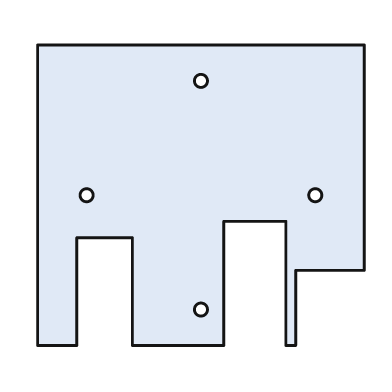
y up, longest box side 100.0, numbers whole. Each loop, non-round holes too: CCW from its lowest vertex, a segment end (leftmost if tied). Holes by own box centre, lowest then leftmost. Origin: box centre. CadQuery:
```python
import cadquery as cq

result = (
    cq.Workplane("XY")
    .moveTo(-50.0, -46.0)
    .lineTo(-38.0, -46.0)
    .lineTo(-38.0, -13.0)
    .lineTo(-21.0, -13.0)
    .lineTo(-21.0, -46.0)
    .lineTo(7.0, -46.0)
    .lineTo(7.0, -8.0)
    .lineTo(26.0, -8.0)
    .lineTo(26.0, -46.0)
    .lineTo(29.0, -46.0)
    .lineTo(29.0, -23.0)
    .lineTo(50.0, -23.0)
    .lineTo(50.0, 46.0)
    .lineTo(-50.0, 46.0)
    .close()
    .moveTo(0.0, -35.0)
    .circle(2.0)
    .moveTo(-35.0, 0.0)
    .circle(2.0)
    .moveTo(35.0, 0.0)
    .circle(2.0)
    .moveTo(0.0, 35.0)
    .circle(2.0)
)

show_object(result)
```